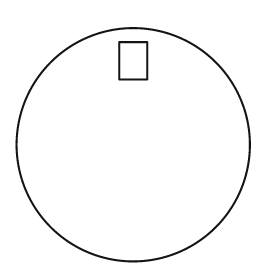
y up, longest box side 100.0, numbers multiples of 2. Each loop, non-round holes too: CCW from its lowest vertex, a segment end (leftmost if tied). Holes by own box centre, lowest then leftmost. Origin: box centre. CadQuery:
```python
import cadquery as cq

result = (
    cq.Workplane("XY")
    .moveTo(0.0, 0.0)
    .circle(50.0)
    .moveTo(-6.0, 28.0)
    .lineTo(6.0, 28.0)
    .lineTo(6.0, 44.0)
    .lineTo(-6.0, 44.0)
    .close()
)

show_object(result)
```